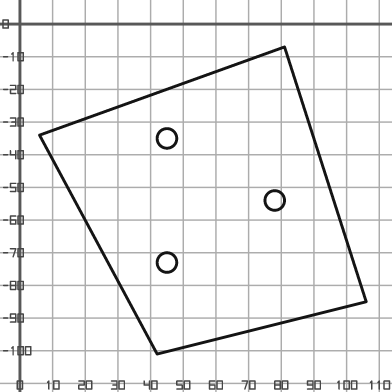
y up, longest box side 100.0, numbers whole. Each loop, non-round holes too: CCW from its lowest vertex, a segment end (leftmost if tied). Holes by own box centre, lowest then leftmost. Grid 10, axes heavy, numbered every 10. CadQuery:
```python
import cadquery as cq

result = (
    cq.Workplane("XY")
    .moveTo(42.0, -101.0)
    .lineTo(106.0, -85.0)
    .lineTo(81.0, -7.0)
    .lineTo(6.0, -34.0)
    .close()
    .moveTo(45.0, -73.0)
    .circle(3.0)
    .moveTo(78.0, -54.0)
    .circle(3.0)
    .moveTo(45.0, -35.0)
    .circle(3.0)
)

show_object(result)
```